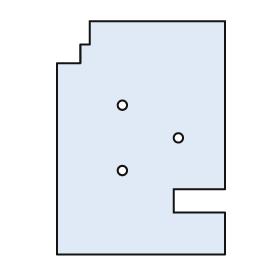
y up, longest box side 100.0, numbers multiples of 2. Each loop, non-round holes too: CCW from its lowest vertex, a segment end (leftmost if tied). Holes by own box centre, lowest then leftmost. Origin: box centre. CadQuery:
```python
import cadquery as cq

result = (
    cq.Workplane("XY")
    .moveTo(-36.0, -50.0)
    .lineTo(36.0, -50.0)
    .lineTo(36.0, -32.0)
    .lineTo(14.0, -32.0)
    .lineTo(14.0, -22.0)
    .lineTo(36.0, -22.0)
    .lineTo(36.0, 50.0)
    .lineTo(-22.0, 50.0)
    .lineTo(-22.0, 40.0)
    .lineTo(-26.0, 40.0)
    .lineTo(-26.0, 32.0)
    .lineTo(-36.0, 32.0)
    .close()
    .moveTo(-8.0, -14.0)
    .circle(2.0)
    .moveTo(16.0, 0.0)
    .circle(2.0)
    .moveTo(-8.0, 14.0)
    .circle(2.0)
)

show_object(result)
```